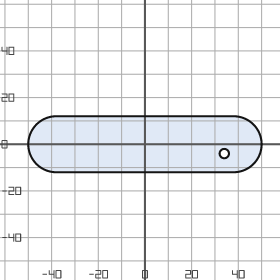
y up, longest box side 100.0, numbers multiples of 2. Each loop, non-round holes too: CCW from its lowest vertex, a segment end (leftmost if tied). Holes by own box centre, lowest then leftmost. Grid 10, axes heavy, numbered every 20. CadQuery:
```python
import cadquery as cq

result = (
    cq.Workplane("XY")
    .moveTo(-38.0, -12.0)
    .lineTo(38.0, -12.0)
    .threePointArc((50.0, 0.0), (38.0, 12.0))
    .lineTo(-38.0, 12.0)
    .threePointArc((-50.0, 0.0), (-38.0, -12.0))
    .close()
    .moveTo(34.0, -4.0)
    .circle(2.0)
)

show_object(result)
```